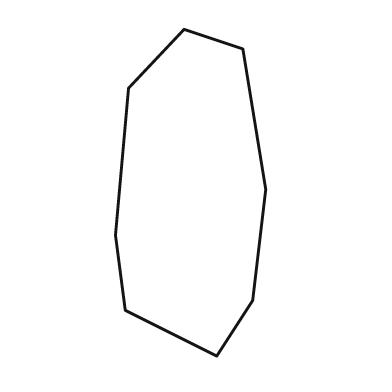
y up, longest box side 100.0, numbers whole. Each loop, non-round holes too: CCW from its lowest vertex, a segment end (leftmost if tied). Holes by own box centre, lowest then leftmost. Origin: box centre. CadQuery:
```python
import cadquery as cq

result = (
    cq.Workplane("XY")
    .moveTo(8.0, -50.0)
    .lineTo(19.0, -33.0)
    .lineTo(23.0, 1.0)
    .lineTo(16.0, 44.0)
    .lineTo(-2.0, 50.0)
    .lineTo(-19.0, 32.0)
    .lineTo(-23.0, -13.0)
    .lineTo(-20.0, -36.0)
    .close()
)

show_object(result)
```